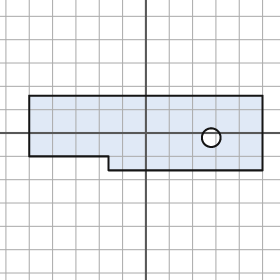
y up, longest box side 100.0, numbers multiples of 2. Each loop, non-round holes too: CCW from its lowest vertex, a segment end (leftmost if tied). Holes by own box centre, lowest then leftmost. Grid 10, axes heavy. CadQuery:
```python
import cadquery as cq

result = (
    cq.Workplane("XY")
    .moveTo(-16.0, -16.0)
    .lineTo(50.0, -16.0)
    .lineTo(50.0, 16.0)
    .lineTo(-50.0, 16.0)
    .lineTo(-50.0, -10.0)
    .lineTo(-16.0, -10.0)
    .close()
    .moveTo(28.0, -2.0)
    .circle(4.0)
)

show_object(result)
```